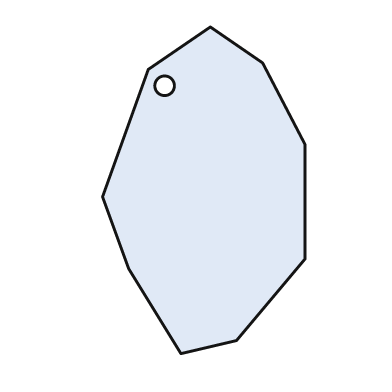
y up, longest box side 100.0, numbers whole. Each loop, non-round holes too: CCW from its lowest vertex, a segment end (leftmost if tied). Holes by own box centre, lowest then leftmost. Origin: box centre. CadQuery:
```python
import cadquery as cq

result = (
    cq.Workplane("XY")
    .moveTo(-7.0, -50.0)
    .lineTo(10.0, -46.0)
    .lineTo(31.0, -21.0)
    .lineTo(31.0, 14.0)
    .lineTo(18.0, 39.0)
    .lineTo(2.0, 50.0)
    .lineTo(-17.0, 37.0)
    .lineTo(-31.0, -2.0)
    .lineTo(-23.0, -24.0)
    .close()
    .moveTo(-12.0, 32.0)
    .circle(3.0)
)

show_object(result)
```